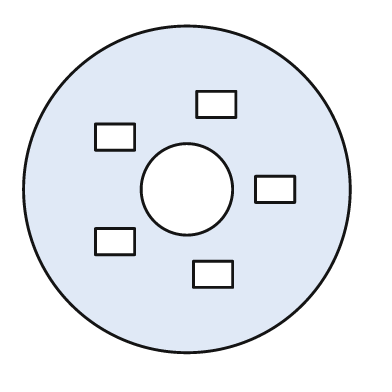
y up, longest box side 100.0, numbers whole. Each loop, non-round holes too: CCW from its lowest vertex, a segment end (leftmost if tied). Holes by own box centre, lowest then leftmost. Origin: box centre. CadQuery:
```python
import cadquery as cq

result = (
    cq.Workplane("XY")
    .moveTo(0.0, 0.0)
    .circle(50.0)
    .moveTo(2.0, -30.0)
    .lineTo(14.0, -30.0)
    .lineTo(14.0, -22.0)
    .lineTo(2.0, -22.0)
    .close()
    .moveTo(-28.0, -20.0)
    .lineTo(-16.0, -20.0)
    .lineTo(-16.0, -12.0)
    .lineTo(-28.0, -12.0)
    .close()
    .moveTo(0.0, 0.0)
    .circle(14.0)
    .moveTo(21.0, -4.0)
    .lineTo(33.0, -4.0)
    .lineTo(33.0, 4.0)
    .lineTo(21.0, 4.0)
    .close()
    .moveTo(-28.0, 12.0)
    .lineTo(-16.0, 12.0)
    .lineTo(-16.0, 20.0)
    .lineTo(-28.0, 20.0)
    .close()
    .moveTo(3.0, 22.0)
    .lineTo(15.0, 22.0)
    .lineTo(15.0, 30.0)
    .lineTo(3.0, 30.0)
    .close()
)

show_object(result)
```